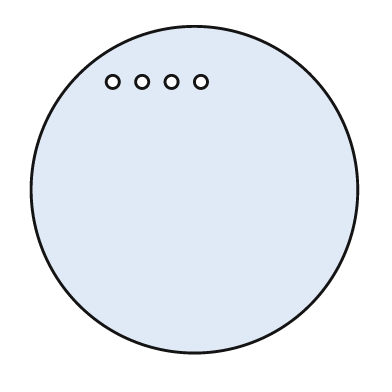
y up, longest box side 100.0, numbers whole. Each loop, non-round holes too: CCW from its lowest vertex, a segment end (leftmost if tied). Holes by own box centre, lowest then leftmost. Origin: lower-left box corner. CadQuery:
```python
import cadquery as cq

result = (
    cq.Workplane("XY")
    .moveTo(50.0, 50.0)
    .circle(50.0)
    .moveTo(25.0, 83.0)
    .circle(2.0)
    .moveTo(34.0, 83.0)
    .circle(2.0)
    .moveTo(43.0, 83.0)
    .circle(2.0)
    .moveTo(52.0, 83.0)
    .circle(2.0)
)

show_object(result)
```